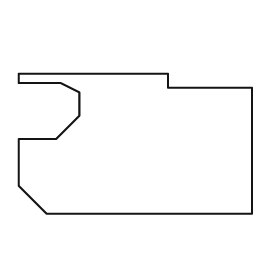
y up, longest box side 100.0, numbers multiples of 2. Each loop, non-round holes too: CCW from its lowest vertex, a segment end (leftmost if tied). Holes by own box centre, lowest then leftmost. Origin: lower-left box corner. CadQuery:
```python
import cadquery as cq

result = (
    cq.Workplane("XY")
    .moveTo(12.0, 0.0)
    .lineTo(100.0, 0.0)
    .lineTo(100.0, 54.0)
    .lineTo(64.0, 54.0)
    .lineTo(64.0, 60.0)
    .lineTo(0.0, 60.0)
    .lineTo(0.0, 56.0)
    .lineTo(18.0, 56.0)
    .lineTo(26.0, 52.0)
    .lineTo(26.0, 42.0)
    .lineTo(16.0, 32.0)
    .lineTo(0.0, 32.0)
    .lineTo(0.0, 12.0)
    .close()
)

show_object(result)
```